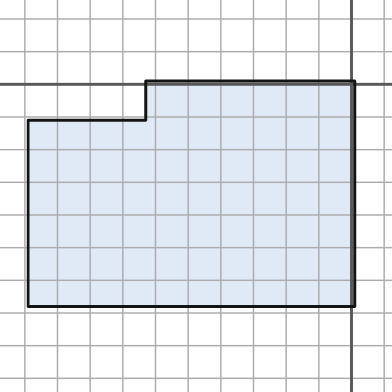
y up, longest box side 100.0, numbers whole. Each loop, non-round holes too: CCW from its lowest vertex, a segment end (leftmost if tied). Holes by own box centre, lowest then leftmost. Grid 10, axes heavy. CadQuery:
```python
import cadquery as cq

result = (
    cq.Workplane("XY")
    .moveTo(-99.0, -68.0)
    .lineTo(1.0, -68.0)
    .lineTo(1.0, 1.0)
    .lineTo(-63.0, 1.0)
    .lineTo(-63.0, -11.0)
    .lineTo(-99.0, -11.0)
    .close()
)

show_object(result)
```